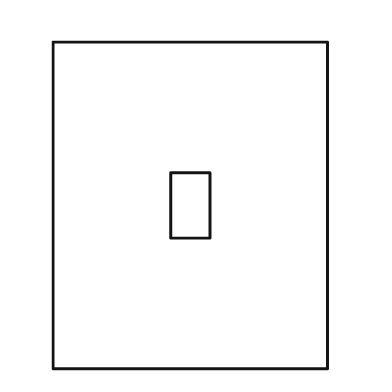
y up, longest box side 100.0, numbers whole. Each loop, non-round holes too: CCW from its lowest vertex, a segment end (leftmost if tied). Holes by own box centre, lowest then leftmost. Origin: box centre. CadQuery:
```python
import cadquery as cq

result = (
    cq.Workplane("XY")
    .moveTo(-42.0, -50.0)
    .lineTo(42.0, -50.0)
    .lineTo(42.0, 50.0)
    .lineTo(-42.0, 50.0)
    .close()
    .moveTo(-6.0, -10.0)
    .lineTo(6.0, -10.0)
    .lineTo(6.0, 10.0)
    .lineTo(-6.0, 10.0)
    .close()
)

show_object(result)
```